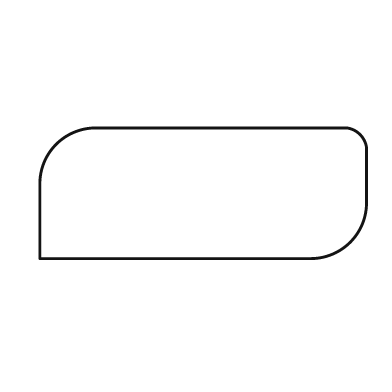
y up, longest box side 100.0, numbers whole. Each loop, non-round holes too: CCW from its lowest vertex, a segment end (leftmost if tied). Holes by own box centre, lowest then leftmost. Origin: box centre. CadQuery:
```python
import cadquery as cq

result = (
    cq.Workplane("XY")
    .moveTo(-50.0, -20.0)
    .lineTo(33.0, -20.0)
    .threePointArc((45.0, -15.0), (50.0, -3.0))
    .lineTo(50.0, 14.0)
    .threePointArc((48.0, 18.0), (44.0, 20.0))
    .lineTo(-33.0, 20.0)
    .threePointArc((-45.0, 15.0), (-50.0, 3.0))
    .close()
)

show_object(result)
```